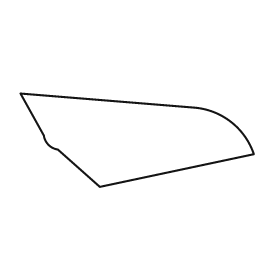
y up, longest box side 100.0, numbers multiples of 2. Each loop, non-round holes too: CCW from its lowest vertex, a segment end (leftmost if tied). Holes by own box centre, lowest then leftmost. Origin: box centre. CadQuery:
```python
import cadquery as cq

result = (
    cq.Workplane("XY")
    .moveTo(-16.0, -20.0)
    .lineTo(50.0, -6.0)
    .threePointArc((40.0, 8.0), (24.0, 14.0))
    .lineTo(-50.0, 20.0)
    .lineTo(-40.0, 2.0)
    .threePointArc((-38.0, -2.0), (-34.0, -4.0))
    .close()
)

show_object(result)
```